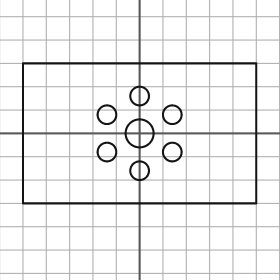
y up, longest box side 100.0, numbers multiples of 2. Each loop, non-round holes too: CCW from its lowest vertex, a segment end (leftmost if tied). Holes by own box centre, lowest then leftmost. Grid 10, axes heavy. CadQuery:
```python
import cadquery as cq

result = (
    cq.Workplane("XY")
    .moveTo(-50.0, -30.0)
    .lineTo(50.0, -30.0)
    .lineTo(50.0, 30.0)
    .lineTo(-50.0, 30.0)
    .close()
    .moveTo(0.0, -16.0)
    .circle(4.0)
    .moveTo(-14.0, -8.0)
    .circle(4.0)
    .moveTo(14.0, -8.0)
    .circle(4.0)
    .moveTo(0.0, 0.0)
    .circle(6.0)
    .moveTo(-14.0, 8.0)
    .circle(4.0)
    .moveTo(14.0, 8.0)
    .circle(4.0)
    .moveTo(0.0, 16.0)
    .circle(4.0)
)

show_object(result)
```